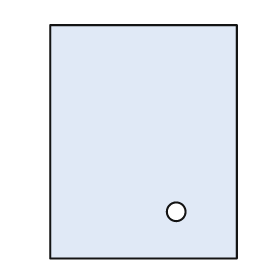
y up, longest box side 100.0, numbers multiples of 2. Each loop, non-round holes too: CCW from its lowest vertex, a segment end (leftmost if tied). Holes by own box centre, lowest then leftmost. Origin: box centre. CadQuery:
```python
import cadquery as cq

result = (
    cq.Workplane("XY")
    .moveTo(-40.0, -50.0)
    .lineTo(40.0, -50.0)
    .lineTo(40.0, 50.0)
    .lineTo(-40.0, 50.0)
    .close()
    .moveTo(14.0, -30.0)
    .circle(4.0)
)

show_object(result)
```